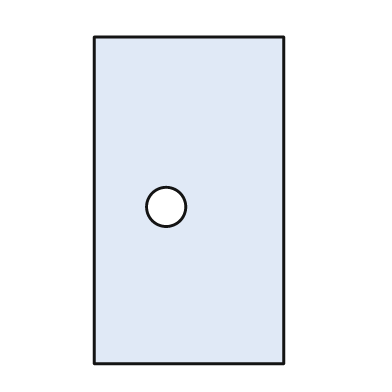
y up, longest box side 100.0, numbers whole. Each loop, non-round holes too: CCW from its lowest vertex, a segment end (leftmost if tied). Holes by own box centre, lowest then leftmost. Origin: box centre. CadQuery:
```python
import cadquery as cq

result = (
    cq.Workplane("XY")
    .moveTo(-29.0, -50.0)
    .lineTo(29.0, -50.0)
    .lineTo(29.0, 50.0)
    .lineTo(-29.0, 50.0)
    .close()
    .moveTo(-7.0, -2.0)
    .circle(6.0)
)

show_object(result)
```